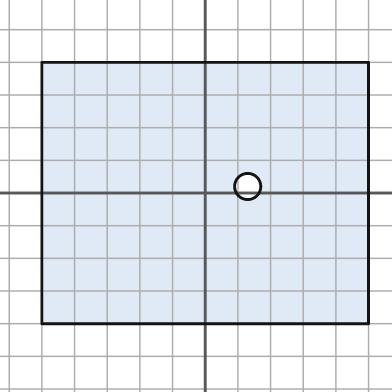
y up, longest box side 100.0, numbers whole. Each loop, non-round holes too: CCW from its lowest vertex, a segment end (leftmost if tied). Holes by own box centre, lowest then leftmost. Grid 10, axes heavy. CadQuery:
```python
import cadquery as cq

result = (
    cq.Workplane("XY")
    .moveTo(-50.0, -40.0)
    .lineTo(50.0, -40.0)
    .lineTo(50.0, 40.0)
    .lineTo(-50.0, 40.0)
    .close()
    .moveTo(13.0, 2.0)
    .circle(4.0)
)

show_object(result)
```